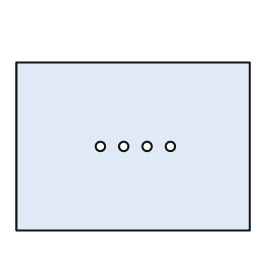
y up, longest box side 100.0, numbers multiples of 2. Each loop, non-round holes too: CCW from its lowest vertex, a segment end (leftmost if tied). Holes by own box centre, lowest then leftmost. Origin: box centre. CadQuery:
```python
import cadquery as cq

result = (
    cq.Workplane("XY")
    .moveTo(-50.0, -36.0)
    .lineTo(50.0, -36.0)
    .lineTo(50.0, 36.0)
    .lineTo(-50.0, 36.0)
    .close()
    .moveTo(-14.0, 0.0)
    .circle(2.0)
    .moveTo(-4.0, 0.0)
    .circle(2.0)
    .moveTo(6.0, 0.0)
    .circle(2.0)
    .moveTo(16.0, 0.0)
    .circle(2.0)
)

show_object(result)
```